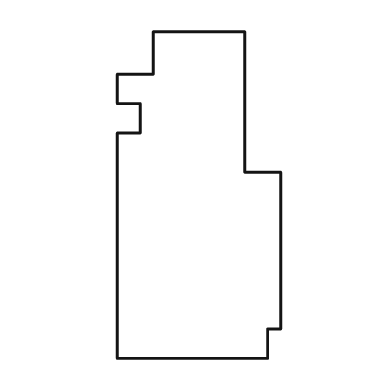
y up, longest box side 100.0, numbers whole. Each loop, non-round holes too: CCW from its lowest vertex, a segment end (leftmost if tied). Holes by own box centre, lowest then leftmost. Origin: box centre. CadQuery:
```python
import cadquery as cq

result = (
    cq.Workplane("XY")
    .moveTo(-25.0, -50.0)
    .lineTo(21.0, -50.0)
    .lineTo(21.0, -41.0)
    .lineTo(25.0, -41.0)
    .lineTo(25.0, 7.0)
    .lineTo(14.0, 7.0)
    .lineTo(14.0, 50.0)
    .lineTo(-14.0, 50.0)
    .lineTo(-14.0, 37.0)
    .lineTo(-25.0, 37.0)
    .lineTo(-25.0, 28.0)
    .lineTo(-18.0, 28.0)
    .lineTo(-18.0, 19.0)
    .lineTo(-25.0, 19.0)
    .close()
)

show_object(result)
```